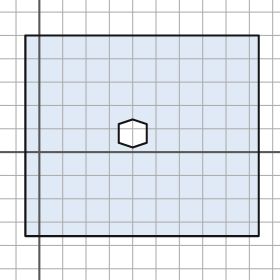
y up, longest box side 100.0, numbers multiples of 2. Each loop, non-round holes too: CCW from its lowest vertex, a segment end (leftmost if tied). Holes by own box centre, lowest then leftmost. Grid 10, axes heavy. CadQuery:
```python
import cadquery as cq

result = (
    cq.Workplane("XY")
    .moveTo(-6.0, -36.0)
    .lineTo(94.0, -36.0)
    .lineTo(94.0, 50.0)
    .lineTo(-6.0, 50.0)
    .close()
    .moveTo(40.0, 2.0)
    .lineTo(46.0, 4.0)
    .lineTo(46.0, 12.0)
    .lineTo(40.0, 14.0)
    .lineTo(34.0, 12.0)
    .lineTo(34.0, 4.0)
    .close()
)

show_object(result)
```